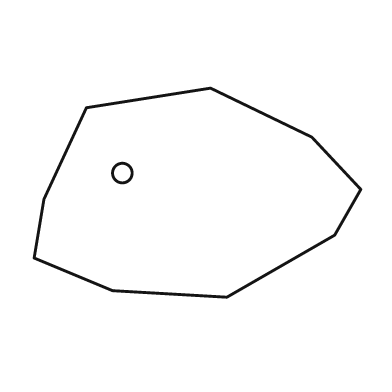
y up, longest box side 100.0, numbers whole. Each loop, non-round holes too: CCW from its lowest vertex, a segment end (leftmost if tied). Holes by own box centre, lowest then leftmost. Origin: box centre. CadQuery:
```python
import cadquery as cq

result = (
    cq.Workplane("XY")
    .moveTo(9.0, -32.0)
    .lineTo(42.0, -13.0)
    .lineTo(50.0, 1.0)
    .lineTo(35.0, 17.0)
    .lineTo(4.0, 32.0)
    .lineTo(-34.0, 26.0)
    .lineTo(-47.0, -2.0)
    .lineTo(-50.0, -20.0)
    .lineTo(-26.0, -30.0)
    .close()
    .moveTo(-23.0, 6.0)
    .circle(3.0)
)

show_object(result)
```